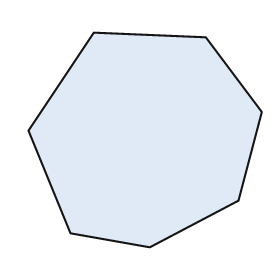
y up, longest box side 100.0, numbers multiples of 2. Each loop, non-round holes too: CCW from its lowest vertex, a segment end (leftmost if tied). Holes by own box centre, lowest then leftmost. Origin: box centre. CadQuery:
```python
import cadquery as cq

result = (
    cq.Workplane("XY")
    .moveTo(2.0, -46.0)
    .lineTo(40.0, -26.0)
    .lineTo(50.0, 12.0)
    .lineTo(26.0, 44.0)
    .lineTo(-22.0, 46.0)
    .lineTo(-50.0, 4.0)
    .lineTo(-32.0, -40.0)
    .close()
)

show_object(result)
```